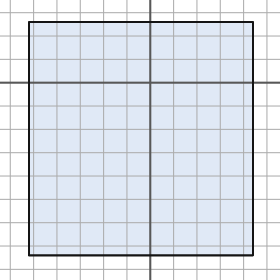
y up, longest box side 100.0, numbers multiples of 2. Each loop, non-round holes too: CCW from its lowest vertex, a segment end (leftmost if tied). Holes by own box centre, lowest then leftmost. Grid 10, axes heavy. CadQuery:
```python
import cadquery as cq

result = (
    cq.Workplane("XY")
    .moveTo(-52.0, -74.0)
    .lineTo(44.0, -74.0)
    .lineTo(44.0, 26.0)
    .lineTo(-52.0, 26.0)
    .close()
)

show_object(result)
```